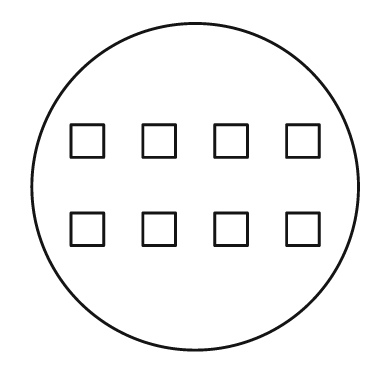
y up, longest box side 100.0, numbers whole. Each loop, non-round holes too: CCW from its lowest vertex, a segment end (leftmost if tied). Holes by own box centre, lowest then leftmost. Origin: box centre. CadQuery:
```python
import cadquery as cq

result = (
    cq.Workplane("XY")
    .moveTo(0.0, 0.0)
    .circle(50.0)
    .moveTo(-38.0, -18.0)
    .lineTo(-28.0, -18.0)
    .lineTo(-28.0, -8.0)
    .lineTo(-38.0, -8.0)
    .close()
    .moveTo(-16.0, -18.0)
    .lineTo(-6.0, -18.0)
    .lineTo(-6.0, -8.0)
    .lineTo(-16.0, -8.0)
    .close()
    .moveTo(6.0, -18.0)
    .lineTo(16.0, -18.0)
    .lineTo(16.0, -8.0)
    .lineTo(6.0, -8.0)
    .close()
    .moveTo(28.0, -18.0)
    .lineTo(38.0, -18.0)
    .lineTo(38.0, -8.0)
    .lineTo(28.0, -8.0)
    .close()
    .moveTo(-38.0, 9.0)
    .lineTo(-28.0, 9.0)
    .lineTo(-28.0, 19.0)
    .lineTo(-38.0, 19.0)
    .close()
    .moveTo(-16.0, 9.0)
    .lineTo(-6.0, 9.0)
    .lineTo(-6.0, 19.0)
    .lineTo(-16.0, 19.0)
    .close()
    .moveTo(6.0, 9.0)
    .lineTo(16.0, 9.0)
    .lineTo(16.0, 19.0)
    .lineTo(6.0, 19.0)
    .close()
    .moveTo(28.0, 9.0)
    .lineTo(38.0, 9.0)
    .lineTo(38.0, 19.0)
    .lineTo(28.0, 19.0)
    .close()
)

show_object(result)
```